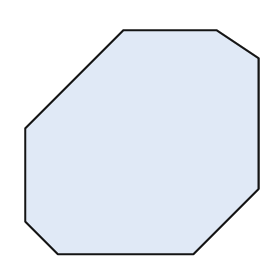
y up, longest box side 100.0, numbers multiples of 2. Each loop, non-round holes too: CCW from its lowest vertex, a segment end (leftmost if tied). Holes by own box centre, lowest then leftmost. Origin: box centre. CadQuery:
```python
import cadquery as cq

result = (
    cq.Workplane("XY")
    .moveTo(-36.0, -48.0)
    .lineTo(22.0, -48.0)
    .lineTo(50.0, -20.0)
    .lineTo(50.0, 36.0)
    .lineTo(32.0, 48.0)
    .lineTo(-8.0, 48.0)
    .lineTo(-50.0, 6.0)
    .lineTo(-50.0, -34.0)
    .close()
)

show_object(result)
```